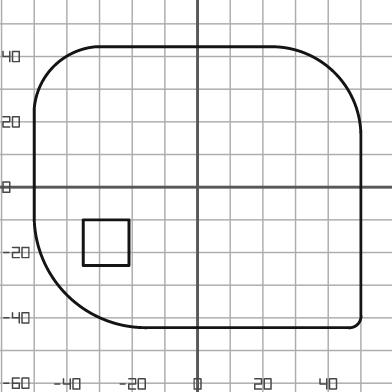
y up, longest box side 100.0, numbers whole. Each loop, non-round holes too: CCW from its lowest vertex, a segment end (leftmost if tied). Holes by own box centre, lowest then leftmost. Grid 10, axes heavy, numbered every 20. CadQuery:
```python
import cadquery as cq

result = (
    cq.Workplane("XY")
    .moveTo(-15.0, -43.0)
    .lineTo(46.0, -43.0)
    .threePointArc((49.0, -42.0), (50.0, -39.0))
    .lineTo(50.0, 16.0)
    .threePointArc((42.0, 35.0), (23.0, 43.0))
    .lineTo(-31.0, 43.0)
    .threePointArc((-44.0, 37.0), (-50.0, 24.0))
    .lineTo(-50.0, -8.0)
    .threePointArc((-40.0, -33.0), (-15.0, -43.0))
    .close()
    .moveTo(-35.0, -24.0)
    .lineTo(-21.0, -24.0)
    .lineTo(-21.0, -10.0)
    .lineTo(-35.0, -10.0)
    .close()
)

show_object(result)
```